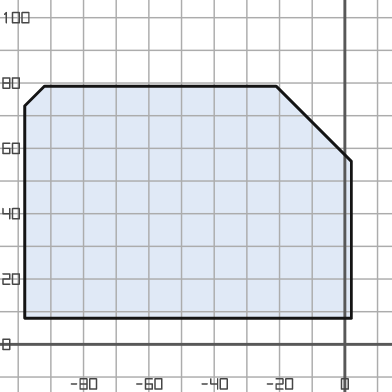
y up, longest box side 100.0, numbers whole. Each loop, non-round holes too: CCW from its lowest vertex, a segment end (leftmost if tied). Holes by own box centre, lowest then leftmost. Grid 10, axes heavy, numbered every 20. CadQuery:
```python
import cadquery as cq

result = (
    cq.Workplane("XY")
    .moveTo(-98.0, 8.0)
    .lineTo(2.0, 8.0)
    .lineTo(2.0, 56.0)
    .lineTo(-21.0, 79.0)
    .lineTo(-92.0, 79.0)
    .lineTo(-98.0, 73.0)
    .close()
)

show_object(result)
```